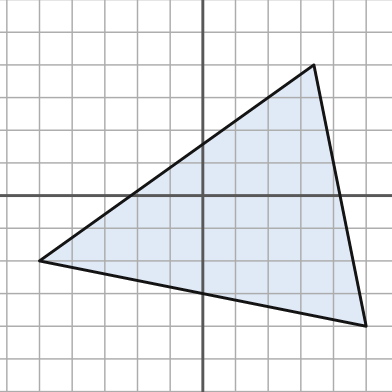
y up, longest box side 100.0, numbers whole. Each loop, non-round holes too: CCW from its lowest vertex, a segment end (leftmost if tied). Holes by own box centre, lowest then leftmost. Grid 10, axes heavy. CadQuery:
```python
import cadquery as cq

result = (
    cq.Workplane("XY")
    .moveTo(50.0, -40.0)
    .lineTo(34.0, 40.0)
    .lineTo(-50.0, -20.0)
    .close()
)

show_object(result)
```